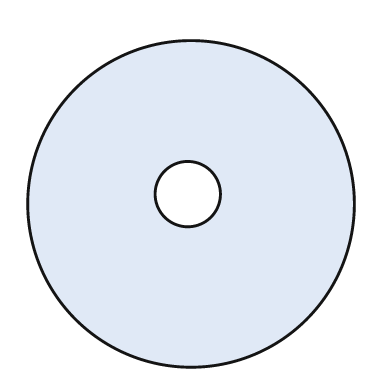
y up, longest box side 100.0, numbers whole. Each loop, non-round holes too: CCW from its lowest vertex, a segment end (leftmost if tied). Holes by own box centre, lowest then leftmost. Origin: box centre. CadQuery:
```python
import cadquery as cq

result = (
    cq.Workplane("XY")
    .moveTo(0.0, 0.0)
    .circle(50.0)
    .moveTo(-1.0, 3.0)
    .circle(10.0)
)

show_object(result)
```